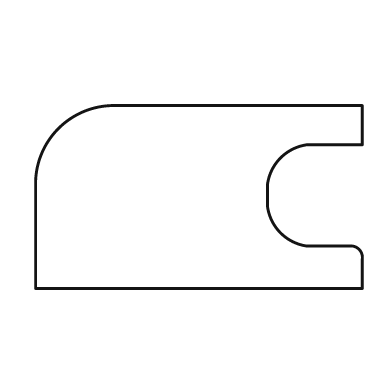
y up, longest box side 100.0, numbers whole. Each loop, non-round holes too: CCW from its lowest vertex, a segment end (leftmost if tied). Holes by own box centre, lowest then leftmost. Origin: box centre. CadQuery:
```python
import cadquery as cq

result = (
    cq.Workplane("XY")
    .moveTo(-50.0, -28.0)
    .lineTo(50.0, -28.0)
    .lineTo(50.0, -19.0)
    .threePointArc((49.0, -16.0), (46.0, -15.0))
    .lineTo(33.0, -15.0)
    .threePointArc((25.0, -11.0), (21.0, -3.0))
    .lineTo(21.0, 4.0)
    .threePointArc((25.0, 12.0), (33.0, 16.0))
    .lineTo(50.0, 16.0)
    .lineTo(50.0, 28.0)
    .lineTo(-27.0, 28.0)
    .threePointArc((-43.0, 21.0), (-50.0, 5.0))
    .close()
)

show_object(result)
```